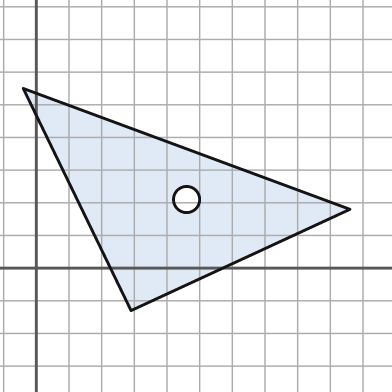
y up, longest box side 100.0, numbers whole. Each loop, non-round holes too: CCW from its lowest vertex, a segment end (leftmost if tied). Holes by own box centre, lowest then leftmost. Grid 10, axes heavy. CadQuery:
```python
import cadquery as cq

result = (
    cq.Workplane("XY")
    .moveTo(29.0, -13.0)
    .lineTo(96.0, 18.0)
    .lineTo(-4.0, 55.0)
    .close()
    .moveTo(46.0, 21.0)
    .circle(4.0)
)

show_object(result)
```